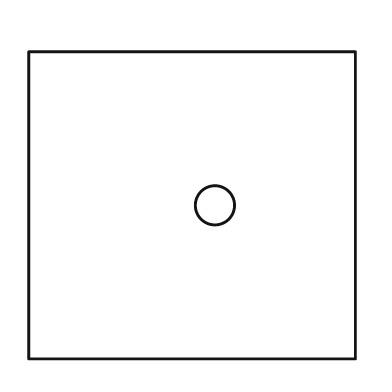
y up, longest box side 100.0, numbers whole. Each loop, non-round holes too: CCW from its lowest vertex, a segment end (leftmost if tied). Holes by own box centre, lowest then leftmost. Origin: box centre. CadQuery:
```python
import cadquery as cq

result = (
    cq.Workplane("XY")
    .moveTo(-50.0, -47.0)
    .lineTo(50.0, -47.0)
    .lineTo(50.0, 47.0)
    .lineTo(-50.0, 47.0)
    .close()
    .moveTo(7.0, 0.0)
    .circle(6.0)
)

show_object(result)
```